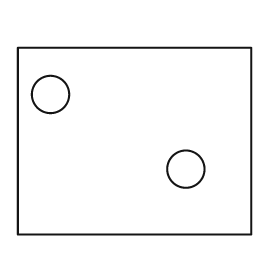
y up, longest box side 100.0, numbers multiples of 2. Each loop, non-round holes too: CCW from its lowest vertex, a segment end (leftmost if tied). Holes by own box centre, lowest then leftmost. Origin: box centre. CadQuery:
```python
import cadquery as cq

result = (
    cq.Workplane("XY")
    .moveTo(-50.0, -40.0)
    .lineTo(50.0, -40.0)
    .lineTo(50.0, 40.0)
    .lineTo(-50.0, 40.0)
    .close()
    .moveTo(22.0, -12.0)
    .circle(8.0)
    .moveTo(-36.0, 20.0)
    .circle(8.0)
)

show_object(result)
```